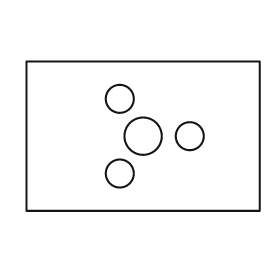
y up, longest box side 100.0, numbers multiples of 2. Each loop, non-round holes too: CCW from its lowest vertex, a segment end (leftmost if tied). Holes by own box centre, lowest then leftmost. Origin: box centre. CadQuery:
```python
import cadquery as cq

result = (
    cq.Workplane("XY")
    .moveTo(-50.0, -32.0)
    .lineTo(50.0, -32.0)
    .lineTo(50.0, 32.0)
    .lineTo(-50.0, 32.0)
    .close()
    .moveTo(-10.0, -16.0)
    .circle(6.0)
    .moveTo(0.0, 0.0)
    .circle(8.0)
    .moveTo(20.0, 0.0)
    .circle(6.0)
    .moveTo(-10.0, 16.0)
    .circle(6.0)
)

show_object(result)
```